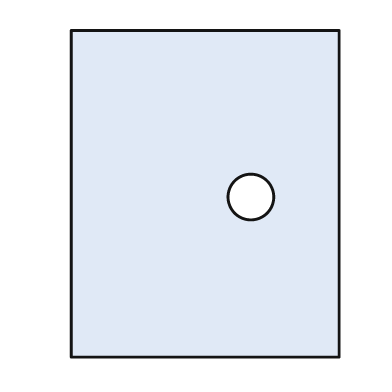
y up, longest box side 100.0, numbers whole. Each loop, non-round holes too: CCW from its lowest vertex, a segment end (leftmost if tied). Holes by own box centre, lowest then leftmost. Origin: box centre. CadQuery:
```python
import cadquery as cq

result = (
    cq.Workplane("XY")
    .moveTo(-41.0, -50.0)
    .lineTo(41.0, -50.0)
    .lineTo(41.0, 50.0)
    .lineTo(-41.0, 50.0)
    .close()
    .moveTo(14.0, -1.0)
    .circle(7.0)
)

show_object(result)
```